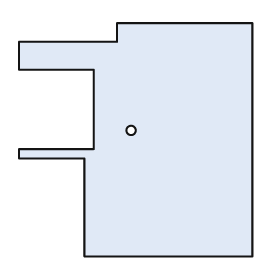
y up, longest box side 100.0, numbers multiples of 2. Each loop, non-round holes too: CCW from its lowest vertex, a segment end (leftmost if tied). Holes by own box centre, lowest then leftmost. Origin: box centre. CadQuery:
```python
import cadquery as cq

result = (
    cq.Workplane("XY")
    .moveTo(-22.0, -50.0)
    .lineTo(50.0, -50.0)
    .lineTo(50.0, 50.0)
    .lineTo(-8.0, 50.0)
    .lineTo(-8.0, 42.0)
    .lineTo(-50.0, 42.0)
    .lineTo(-50.0, 30.0)
    .lineTo(-18.0, 30.0)
    .lineTo(-18.0, -4.0)
    .lineTo(-50.0, -4.0)
    .lineTo(-50.0, -8.0)
    .lineTo(-22.0, -8.0)
    .close()
    .moveTo(-2.0, 4.0)
    .circle(2.0)
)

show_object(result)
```